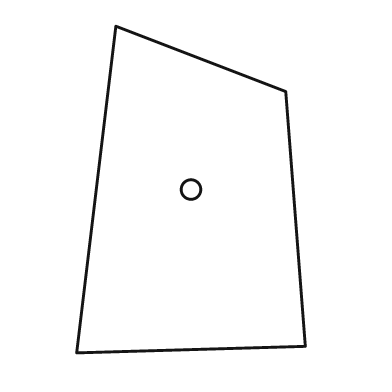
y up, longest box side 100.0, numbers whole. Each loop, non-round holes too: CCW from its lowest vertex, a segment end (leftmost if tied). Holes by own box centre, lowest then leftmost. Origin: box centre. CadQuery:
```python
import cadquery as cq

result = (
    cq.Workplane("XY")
    .moveTo(-35.0, -50.0)
    .lineTo(35.0, -48.0)
    .lineTo(29.0, 30.0)
    .lineTo(-23.0, 50.0)
    .close()
    .moveTo(0.0, 0.0)
    .circle(3.0)
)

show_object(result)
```